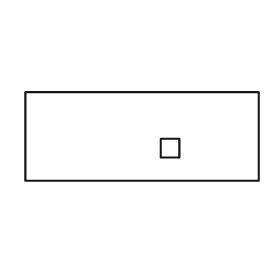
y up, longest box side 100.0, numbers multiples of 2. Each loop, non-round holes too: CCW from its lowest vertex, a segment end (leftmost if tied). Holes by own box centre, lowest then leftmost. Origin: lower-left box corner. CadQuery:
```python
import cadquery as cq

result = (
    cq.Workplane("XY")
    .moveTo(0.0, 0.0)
    .lineTo(100.0, 0.0)
    .lineTo(100.0, 38.0)
    .lineTo(0.0, 38.0)
    .close()
    .moveTo(58.0, 10.0)
    .lineTo(66.0, 10.0)
    .lineTo(66.0, 18.0)
    .lineTo(58.0, 18.0)
    .close()
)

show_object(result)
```